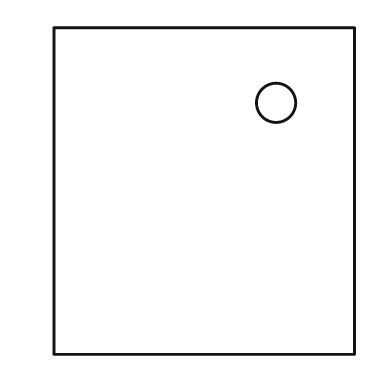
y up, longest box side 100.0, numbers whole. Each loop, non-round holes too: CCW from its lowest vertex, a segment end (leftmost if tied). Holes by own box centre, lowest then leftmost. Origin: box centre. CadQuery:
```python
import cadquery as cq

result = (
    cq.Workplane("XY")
    .moveTo(-46.0, -50.0)
    .lineTo(46.0, -50.0)
    .lineTo(46.0, 50.0)
    .lineTo(-46.0, 50.0)
    .close()
    .moveTo(22.0, 27.0)
    .circle(6.0)
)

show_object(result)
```